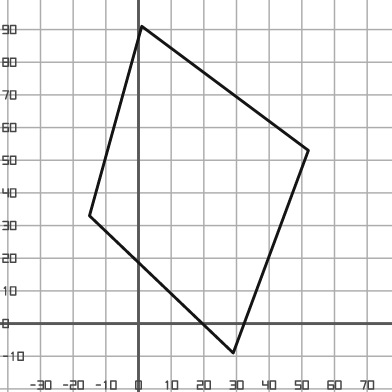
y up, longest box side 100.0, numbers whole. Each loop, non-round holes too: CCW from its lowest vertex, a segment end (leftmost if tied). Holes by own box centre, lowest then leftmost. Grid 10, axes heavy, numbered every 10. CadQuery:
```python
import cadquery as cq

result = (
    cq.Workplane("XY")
    .moveTo(29.0, -9.0)
    .lineTo(52.0, 53.0)
    .lineTo(1.0, 91.0)
    .lineTo(-15.0, 33.0)
    .close()
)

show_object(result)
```